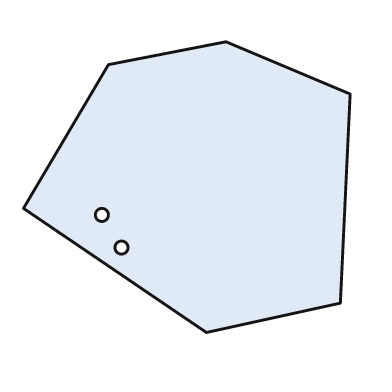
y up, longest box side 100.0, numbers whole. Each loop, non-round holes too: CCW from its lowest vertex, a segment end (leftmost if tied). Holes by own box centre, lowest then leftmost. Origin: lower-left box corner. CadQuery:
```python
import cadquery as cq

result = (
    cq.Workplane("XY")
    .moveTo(56.0, 0.0)
    .lineTo(97.0, 9.0)
    .lineTo(100.0, 73.0)
    .lineTo(62.0, 89.0)
    .lineTo(26.0, 82.0)
    .lineTo(0.0, 38.0)
    .close()
    .moveTo(30.0, 26.0)
    .circle(2.0)
    .moveTo(24.0, 36.0)
    .circle(2.0)
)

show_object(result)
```